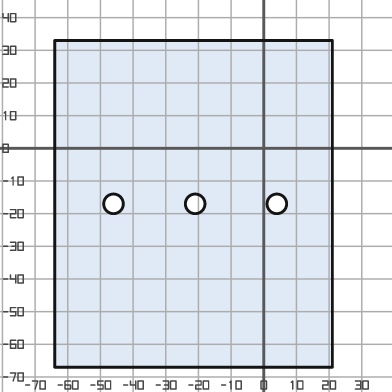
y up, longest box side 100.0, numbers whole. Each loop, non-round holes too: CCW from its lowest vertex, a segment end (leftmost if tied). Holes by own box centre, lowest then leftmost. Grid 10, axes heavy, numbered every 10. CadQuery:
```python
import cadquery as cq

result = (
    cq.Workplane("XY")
    .moveTo(-64.0, -67.0)
    .lineTo(21.0, -67.0)
    .lineTo(21.0, 33.0)
    .lineTo(-64.0, 33.0)
    .close()
    .moveTo(-46.0, -17.0)
    .circle(3.0)
    .moveTo(-21.0, -17.0)
    .circle(3.0)
    .moveTo(4.0, -17.0)
    .circle(3.0)
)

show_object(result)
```